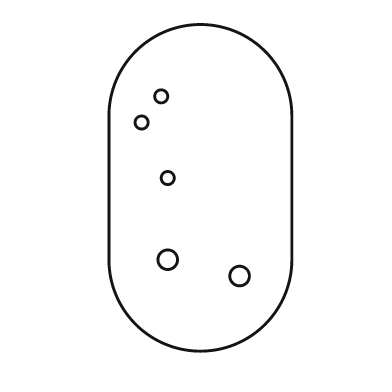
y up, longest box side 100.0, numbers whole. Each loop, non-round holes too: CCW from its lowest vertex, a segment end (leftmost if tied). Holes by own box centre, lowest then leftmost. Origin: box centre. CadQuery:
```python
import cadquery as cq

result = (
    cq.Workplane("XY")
    .moveTo(-28.0, -22.0)
    .threePointArc((0.0, -50.0), (28.0, -22.0))
    .lineTo(28.0, 22.0)
    .threePointArc((0.0, 50.0), (-28.0, 22.0))
    .close()
    .moveTo(12.0, -27.0)
    .circle(3.0)
    .moveTo(-10.0, -22.0)
    .circle(3.0)
    .moveTo(-10.0, 3.0)
    .circle(2.0)
    .moveTo(-18.0, 20.0)
    .circle(2.0)
    .moveTo(-12.0, 28.0)
    .circle(2.0)
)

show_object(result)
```